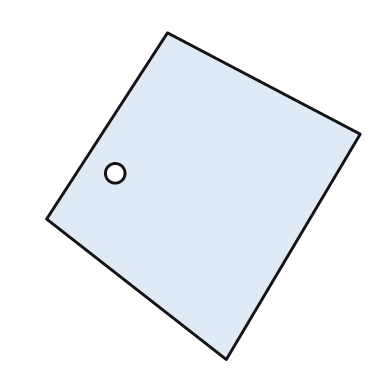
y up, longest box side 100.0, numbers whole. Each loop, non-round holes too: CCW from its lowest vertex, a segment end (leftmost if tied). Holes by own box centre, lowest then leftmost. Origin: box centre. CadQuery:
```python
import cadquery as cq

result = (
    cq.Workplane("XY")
    .moveTo(7.0, -50.0)
    .lineTo(48.0, 19.0)
    .lineTo(-11.0, 50.0)
    .lineTo(-48.0, -7.0)
    .close()
    .moveTo(-27.0, 7.0)
    .circle(3.0)
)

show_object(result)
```